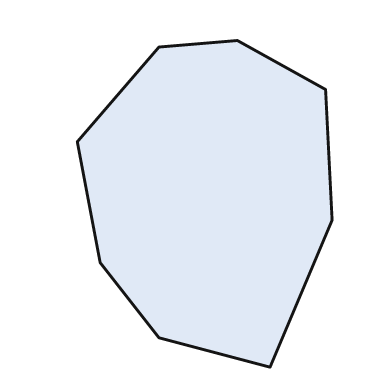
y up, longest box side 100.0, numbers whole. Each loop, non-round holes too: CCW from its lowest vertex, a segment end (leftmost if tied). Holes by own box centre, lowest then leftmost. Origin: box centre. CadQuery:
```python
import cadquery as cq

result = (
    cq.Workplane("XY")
    .moveTo(20.0, -50.0)
    .lineTo(39.0, -5.0)
    .lineTo(37.0, 35.0)
    .lineTo(10.0, 50.0)
    .lineTo(-14.0, 48.0)
    .lineTo(-39.0, 19.0)
    .lineTo(-32.0, -18.0)
    .lineTo(-14.0, -41.0)
    .close()
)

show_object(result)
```